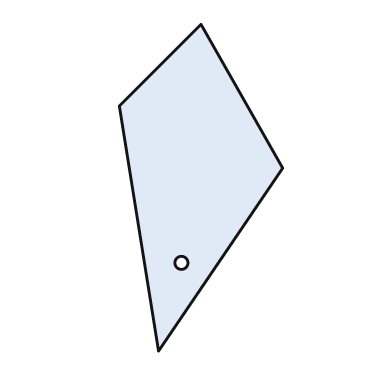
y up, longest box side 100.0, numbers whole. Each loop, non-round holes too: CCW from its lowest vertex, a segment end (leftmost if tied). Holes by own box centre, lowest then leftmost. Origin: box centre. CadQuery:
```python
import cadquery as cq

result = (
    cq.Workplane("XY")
    .moveTo(-13.0, -50.0)
    .lineTo(25.0, 6.0)
    .lineTo(0.0, 50.0)
    .lineTo(-25.0, 25.0)
    .close()
    .moveTo(-6.0, -23.0)
    .circle(2.0)
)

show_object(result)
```